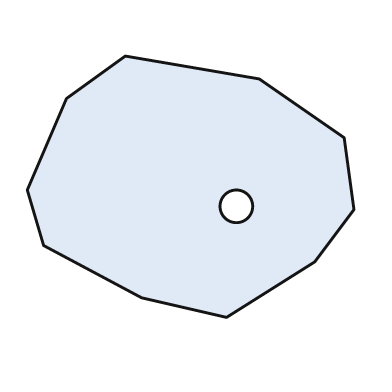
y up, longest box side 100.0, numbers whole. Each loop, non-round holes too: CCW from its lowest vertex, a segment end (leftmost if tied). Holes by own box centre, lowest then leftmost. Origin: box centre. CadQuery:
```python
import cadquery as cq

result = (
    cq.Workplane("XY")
    .moveTo(11.0, -40.0)
    .lineTo(38.0, -23.0)
    .lineTo(50.0, -7.0)
    .lineTo(47.0, 15.0)
    .lineTo(21.0, 33.0)
    .lineTo(-20.0, 40.0)
    .lineTo(-38.0, 27.0)
    .lineTo(-50.0, -1.0)
    .lineTo(-45.0, -18.0)
    .lineTo(-15.0, -34.0)
    .close()
    .moveTo(14.0, -6.0)
    .circle(5.0)
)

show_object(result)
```